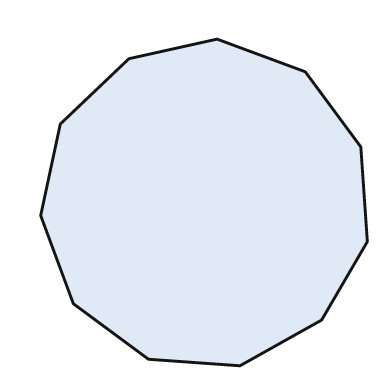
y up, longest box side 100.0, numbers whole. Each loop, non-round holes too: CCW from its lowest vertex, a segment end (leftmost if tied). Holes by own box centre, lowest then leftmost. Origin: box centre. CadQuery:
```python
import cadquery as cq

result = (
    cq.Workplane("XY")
    .moveTo(11.0, -50.0)
    .lineTo(36.0, -36.0)
    .lineTo(50.0, -12.0)
    .lineTo(48.0, 17.0)
    .lineTo(31.0, 40.0)
    .lineTo(4.0, 50.0)
    .lineTo(-23.0, 44.0)
    .lineTo(-44.0, 24.0)
    .lineTo(-50.0, -4.0)
    .lineTo(-40.0, -31.0)
    .lineTo(-17.0, -48.0)
    .close()
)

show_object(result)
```